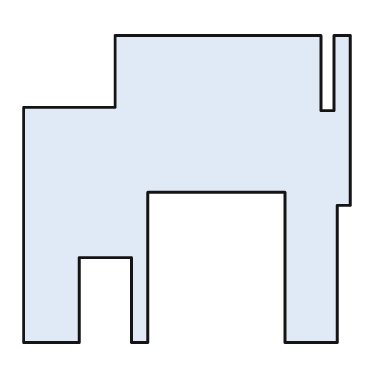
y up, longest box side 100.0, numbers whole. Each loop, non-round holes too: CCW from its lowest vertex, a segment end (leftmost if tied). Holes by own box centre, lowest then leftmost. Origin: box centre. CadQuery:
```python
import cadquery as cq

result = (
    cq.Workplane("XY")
    .moveTo(-50.0, -47.0)
    .lineTo(-33.0, -47.0)
    .lineTo(-33.0, -21.0)
    .lineTo(-17.0, -21.0)
    .lineTo(-17.0, -47.0)
    .lineTo(-12.0, -47.0)
    .lineTo(-12.0, -1.0)
    .lineTo(30.0, -1.0)
    .lineTo(30.0, -47.0)
    .lineTo(46.0, -47.0)
    .lineTo(46.0, -5.0)
    .lineTo(50.0, -5.0)
    .lineTo(50.0, 47.0)
    .lineTo(45.0, 47.0)
    .lineTo(45.0, 24.0)
    .lineTo(41.0, 24.0)
    .lineTo(41.0, 47.0)
    .lineTo(-22.0, 47.0)
    .lineTo(-22.0, 25.0)
    .lineTo(-50.0, 25.0)
    .close()
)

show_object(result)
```